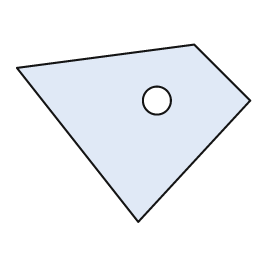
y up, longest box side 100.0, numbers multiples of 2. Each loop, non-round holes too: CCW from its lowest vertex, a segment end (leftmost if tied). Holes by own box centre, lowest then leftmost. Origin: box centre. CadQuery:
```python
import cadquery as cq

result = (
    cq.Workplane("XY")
    .moveTo(2.0, -38.0)
    .lineTo(50.0, 14.0)
    .lineTo(26.0, 38.0)
    .lineTo(-50.0, 28.0)
    .close()
    .moveTo(10.0, 14.0)
    .circle(6.0)
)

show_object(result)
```